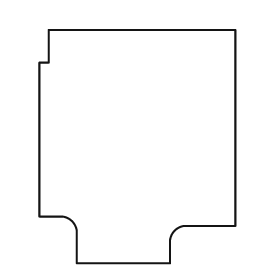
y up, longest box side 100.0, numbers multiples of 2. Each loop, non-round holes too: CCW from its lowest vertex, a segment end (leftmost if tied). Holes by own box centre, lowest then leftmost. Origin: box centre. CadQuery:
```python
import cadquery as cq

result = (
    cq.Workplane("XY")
    .moveTo(-26.0, -50.0)
    .lineTo(14.0, -50.0)
    .lineTo(14.0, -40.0)
    .threePointArc((16.0, -36.0), (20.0, -34.0))
    .lineTo(42.0, -34.0)
    .lineTo(42.0, 50.0)
    .lineTo(-38.0, 50.0)
    .lineTo(-38.0, 36.0)
    .lineTo(-42.0, 36.0)
    .lineTo(-42.0, -30.0)
    .lineTo(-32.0, -30.0)
    .threePointArc((-28.0, -32.0), (-26.0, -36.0))
    .close()
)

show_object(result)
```